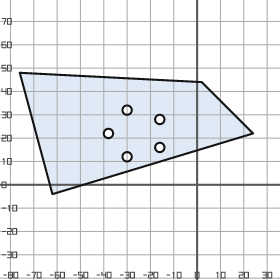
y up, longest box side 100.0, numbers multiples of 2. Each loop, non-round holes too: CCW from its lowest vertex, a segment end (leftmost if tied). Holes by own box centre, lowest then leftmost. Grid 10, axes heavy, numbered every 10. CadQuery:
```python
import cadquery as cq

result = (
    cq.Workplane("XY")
    .moveTo(-62.0, -4.0)
    .lineTo(24.0, 22.0)
    .lineTo(2.0, 44.0)
    .lineTo(-76.0, 48.0)
    .close()
    .moveTo(-30.0, 12.0)
    .circle(2.0)
    .moveTo(-16.0, 16.0)
    .circle(2.0)
    .moveTo(-38.0, 22.0)
    .circle(2.0)
    .moveTo(-16.0, 28.0)
    .circle(2.0)
    .moveTo(-30.0, 32.0)
    .circle(2.0)
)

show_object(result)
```